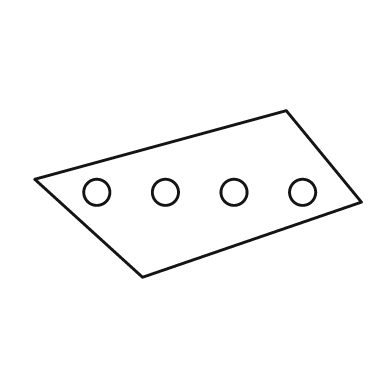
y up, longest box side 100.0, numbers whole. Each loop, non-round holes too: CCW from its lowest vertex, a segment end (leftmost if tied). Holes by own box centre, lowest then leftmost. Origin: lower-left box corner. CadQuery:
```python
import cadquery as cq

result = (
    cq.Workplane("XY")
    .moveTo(33.0, 0.0)
    .lineTo(100.0, 23.0)
    .lineTo(77.0, 51.0)
    .lineTo(0.0, 30.0)
    .close()
    .moveTo(19.0, 26.0)
    .circle(4.0)
    .moveTo(40.0, 26.0)
    .circle(4.0)
    .moveTo(61.0, 26.0)
    .circle(4.0)
    .moveTo(82.0, 26.0)
    .circle(4.0)
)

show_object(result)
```